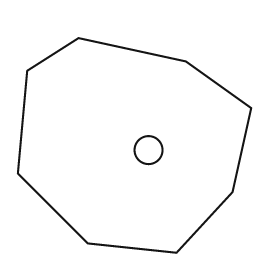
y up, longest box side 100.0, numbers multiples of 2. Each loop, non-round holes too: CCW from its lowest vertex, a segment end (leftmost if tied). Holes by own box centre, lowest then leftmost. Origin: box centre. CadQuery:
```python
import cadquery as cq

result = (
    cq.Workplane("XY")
    .moveTo(18.0, -46.0)
    .lineTo(42.0, -20.0)
    .lineTo(50.0, 16.0)
    .lineTo(22.0, 36.0)
    .lineTo(-24.0, 46.0)
    .lineTo(-46.0, 32.0)
    .lineTo(-50.0, -12.0)
    .lineTo(-20.0, -42.0)
    .close()
    .moveTo(6.0, -2.0)
    .circle(6.0)
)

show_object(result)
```